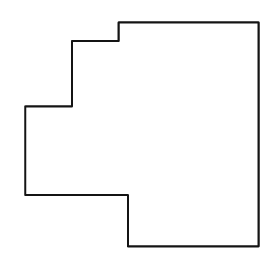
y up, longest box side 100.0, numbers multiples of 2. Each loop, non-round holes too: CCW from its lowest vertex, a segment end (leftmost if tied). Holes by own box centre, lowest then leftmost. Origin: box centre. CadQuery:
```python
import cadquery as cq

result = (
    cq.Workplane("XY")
    .moveTo(-6.0, -48.0)
    .lineTo(50.0, -48.0)
    .lineTo(50.0, 48.0)
    .lineTo(-10.0, 48.0)
    .lineTo(-10.0, 40.0)
    .lineTo(-30.0, 40.0)
    .lineTo(-30.0, 12.0)
    .lineTo(-50.0, 12.0)
    .lineTo(-50.0, -26.0)
    .lineTo(-6.0, -26.0)
    .close()
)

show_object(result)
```